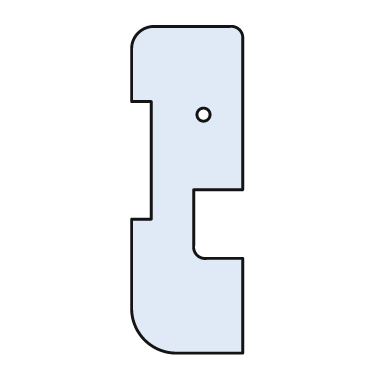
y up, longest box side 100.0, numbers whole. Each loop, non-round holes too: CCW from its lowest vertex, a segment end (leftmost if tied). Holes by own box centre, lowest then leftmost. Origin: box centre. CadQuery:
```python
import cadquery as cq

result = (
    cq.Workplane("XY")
    .moveTo(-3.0, -50.0)
    .lineTo(17.0, -50.0)
    .lineTo(17.0, -21.0)
    .lineTo(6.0, -21.0)
    .threePointArc((3.0, -20.0), (2.0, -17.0))
    .lineTo(2.0, 0.0)
    .lineTo(17.0, 0.0)
    .lineTo(17.0, 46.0)
    .threePointArc((16.0, 49.0), (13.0, 50.0))
    .lineTo(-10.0, 50.0)
    .threePointArc((-15.0, 48.0), (-17.0, 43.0))
    .lineTo(-17.0, 27.0)
    .lineTo(-11.0, 27.0)
    .lineTo(-11.0, -9.0)
    .lineTo(-17.0, -9.0)
    .lineTo(-17.0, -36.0)
    .threePointArc((-13.0, -46.0), (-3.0, -50.0))
    .close()
    .moveTo(5.0, 23.0)
    .circle(2.0)
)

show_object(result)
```